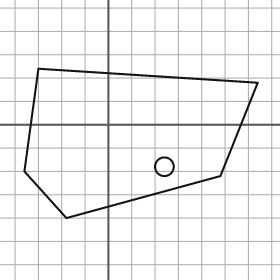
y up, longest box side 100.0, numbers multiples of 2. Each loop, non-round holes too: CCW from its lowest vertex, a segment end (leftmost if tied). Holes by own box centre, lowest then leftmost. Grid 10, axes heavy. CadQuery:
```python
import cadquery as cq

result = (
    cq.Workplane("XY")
    .moveTo(-18.0, -40.0)
    .lineTo(48.0, -22.0)
    .lineTo(64.0, 18.0)
    .lineTo(-30.0, 24.0)
    .lineTo(-36.0, -20.0)
    .close()
    .moveTo(24.0, -18.0)
    .circle(4.0)
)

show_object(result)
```